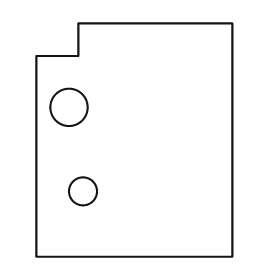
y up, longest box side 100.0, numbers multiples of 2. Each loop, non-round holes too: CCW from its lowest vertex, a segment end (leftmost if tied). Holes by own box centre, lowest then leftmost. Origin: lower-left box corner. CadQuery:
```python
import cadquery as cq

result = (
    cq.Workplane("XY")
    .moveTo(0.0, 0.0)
    .lineTo(84.0, 0.0)
    .lineTo(84.0, 100.0)
    .lineTo(18.0, 100.0)
    .lineTo(18.0, 86.0)
    .lineTo(0.0, 86.0)
    .close()
    .moveTo(20.0, 28.0)
    .circle(6.0)
    .moveTo(14.0, 64.0)
    .circle(8.0)
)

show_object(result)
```